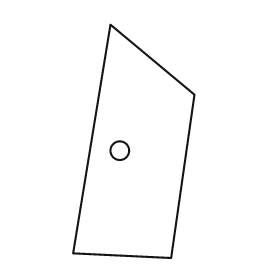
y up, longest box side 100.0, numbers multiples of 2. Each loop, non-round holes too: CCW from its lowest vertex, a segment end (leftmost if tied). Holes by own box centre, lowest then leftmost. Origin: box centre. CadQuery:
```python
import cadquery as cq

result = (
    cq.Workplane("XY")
    .moveTo(16.0, -50.0)
    .lineTo(26.0, 20.0)
    .lineTo(-10.0, 50.0)
    .lineTo(-26.0, -48.0)
    .close()
    .moveTo(-6.0, -4.0)
    .circle(4.0)
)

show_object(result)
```